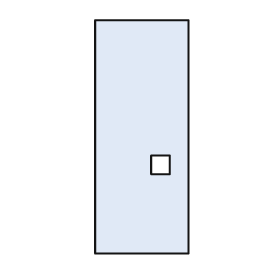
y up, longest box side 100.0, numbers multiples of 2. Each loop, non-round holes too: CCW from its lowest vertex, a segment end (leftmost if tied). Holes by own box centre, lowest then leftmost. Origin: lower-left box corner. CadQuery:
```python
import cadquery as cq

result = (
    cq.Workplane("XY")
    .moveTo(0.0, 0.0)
    .lineTo(40.0, 0.0)
    .lineTo(40.0, 100.0)
    .lineTo(0.0, 100.0)
    .close()
    .moveTo(24.0, 34.0)
    .lineTo(32.0, 34.0)
    .lineTo(32.0, 42.0)
    .lineTo(24.0, 42.0)
    .close()
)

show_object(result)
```